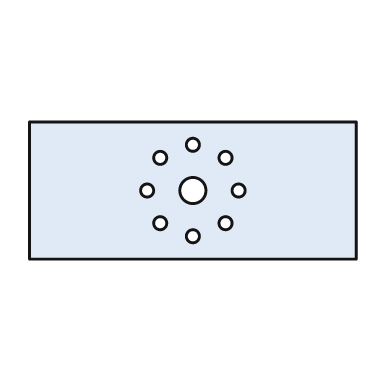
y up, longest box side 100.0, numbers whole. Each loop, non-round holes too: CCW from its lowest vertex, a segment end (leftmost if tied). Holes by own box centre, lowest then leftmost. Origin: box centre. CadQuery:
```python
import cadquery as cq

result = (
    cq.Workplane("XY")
    .moveTo(-50.0, -21.0)
    .lineTo(50.0, -21.0)
    .lineTo(50.0, 21.0)
    .lineTo(-50.0, 21.0)
    .close()
    .moveTo(0.0, -14.0)
    .circle(2.0)
    .moveTo(-10.0, -10.0)
    .circle(2.0)
    .moveTo(10.0, -10.0)
    .circle(2.0)
    .moveTo(-14.0, 0.0)
    .circle(2.0)
    .moveTo(0.0, 0.0)
    .circle(4.0)
    .moveTo(14.0, 0.0)
    .circle(2.0)
    .moveTo(-10.0, 10.0)
    .circle(2.0)
    .moveTo(10.0, 10.0)
    .circle(2.0)
    .moveTo(0.0, 14.0)
    .circle(2.0)
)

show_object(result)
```